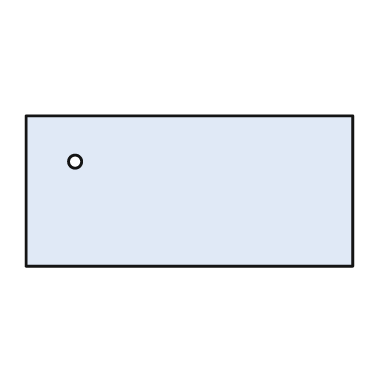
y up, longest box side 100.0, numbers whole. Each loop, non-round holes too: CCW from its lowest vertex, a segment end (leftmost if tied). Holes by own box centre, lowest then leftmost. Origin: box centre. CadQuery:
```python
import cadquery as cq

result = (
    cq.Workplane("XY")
    .moveTo(-50.0, -23.0)
    .lineTo(50.0, -23.0)
    .lineTo(50.0, 23.0)
    .lineTo(-50.0, 23.0)
    .close()
    .moveTo(-35.0, 9.0)
    .circle(2.0)
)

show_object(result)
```